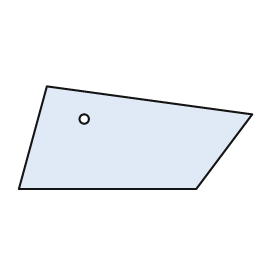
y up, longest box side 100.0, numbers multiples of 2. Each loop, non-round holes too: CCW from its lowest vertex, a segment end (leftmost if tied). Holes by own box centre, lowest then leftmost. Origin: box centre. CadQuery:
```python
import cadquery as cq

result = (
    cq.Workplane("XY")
    .moveTo(-50.0, -22.0)
    .lineTo(26.0, -22.0)
    .lineTo(50.0, 10.0)
    .lineTo(-38.0, 22.0)
    .close()
    .moveTo(-22.0, 8.0)
    .circle(2.0)
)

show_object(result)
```